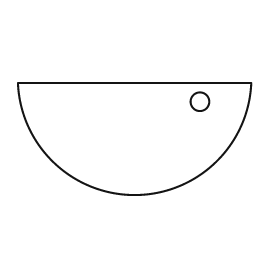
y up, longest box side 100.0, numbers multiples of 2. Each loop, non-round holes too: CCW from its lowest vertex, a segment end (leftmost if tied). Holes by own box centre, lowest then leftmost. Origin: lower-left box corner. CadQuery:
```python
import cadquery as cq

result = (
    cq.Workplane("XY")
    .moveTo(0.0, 48.0)
    .threePointArc((50.0, 0.0), (100.0, 48.0))
    .close()
    .moveTo(78.0, 40.0)
    .circle(4.0)
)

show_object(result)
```